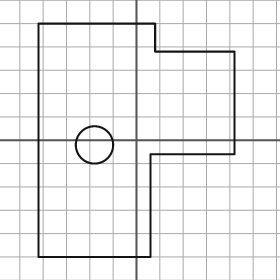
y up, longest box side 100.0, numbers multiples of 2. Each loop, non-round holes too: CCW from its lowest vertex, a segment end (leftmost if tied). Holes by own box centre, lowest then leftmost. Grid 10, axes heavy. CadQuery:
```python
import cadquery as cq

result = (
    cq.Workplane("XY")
    .moveTo(-42.0, -50.0)
    .lineTo(6.0, -50.0)
    .lineTo(6.0, -6.0)
    .lineTo(42.0, -6.0)
    .lineTo(42.0, 38.0)
    .lineTo(8.0, 38.0)
    .lineTo(8.0, 50.0)
    .lineTo(-42.0, 50.0)
    .close()
    .moveTo(-18.0, -2.0)
    .circle(8.0)
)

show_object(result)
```